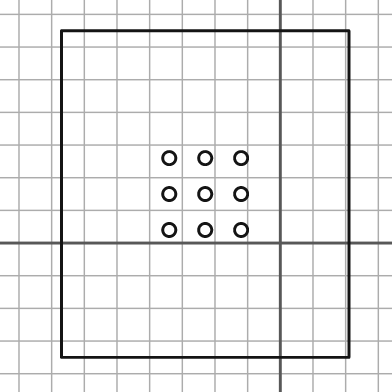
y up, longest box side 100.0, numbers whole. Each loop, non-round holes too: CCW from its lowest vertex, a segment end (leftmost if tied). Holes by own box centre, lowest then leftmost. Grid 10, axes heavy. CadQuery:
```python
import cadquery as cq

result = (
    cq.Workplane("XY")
    .moveTo(-67.0, -35.0)
    .lineTo(21.0, -35.0)
    .lineTo(21.0, 65.0)
    .lineTo(-67.0, 65.0)
    .close()
    .moveTo(-34.0, 4.0)
    .circle(2.0)
    .moveTo(-23.0, 4.0)
    .circle(2.0)
    .moveTo(-12.0, 4.0)
    .circle(2.0)
    .moveTo(-34.0, 15.0)
    .circle(2.0)
    .moveTo(-23.0, 15.0)
    .circle(2.0)
    .moveTo(-12.0, 15.0)
    .circle(2.0)
    .moveTo(-34.0, 26.0)
    .circle(2.0)
    .moveTo(-23.0, 26.0)
    .circle(2.0)
    .moveTo(-12.0, 26.0)
    .circle(2.0)
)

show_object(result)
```